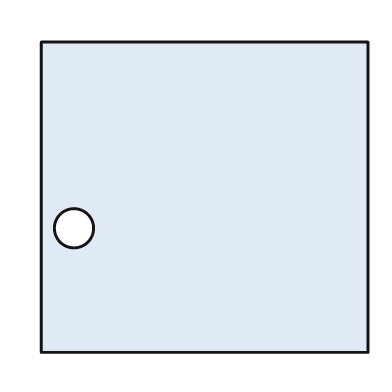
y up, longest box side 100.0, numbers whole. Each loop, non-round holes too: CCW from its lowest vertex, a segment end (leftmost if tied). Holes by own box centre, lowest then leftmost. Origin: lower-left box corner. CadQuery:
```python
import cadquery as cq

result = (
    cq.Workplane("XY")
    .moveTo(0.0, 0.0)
    .lineTo(100.0, 0.0)
    .lineTo(100.0, 95.0)
    .lineTo(0.0, 95.0)
    .close()
    .moveTo(10.0, 38.0)
    .circle(6.0)
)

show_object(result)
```